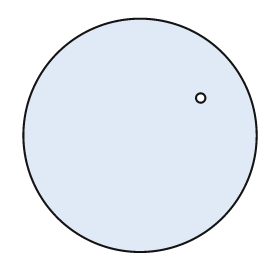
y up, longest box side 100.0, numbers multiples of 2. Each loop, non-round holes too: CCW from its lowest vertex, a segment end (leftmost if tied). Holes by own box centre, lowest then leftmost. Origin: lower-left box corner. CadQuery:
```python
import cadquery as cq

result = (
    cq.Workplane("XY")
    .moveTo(50.0, 50.0)
    .circle(50.0)
    .moveTo(76.0, 66.0)
    .circle(2.0)
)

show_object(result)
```